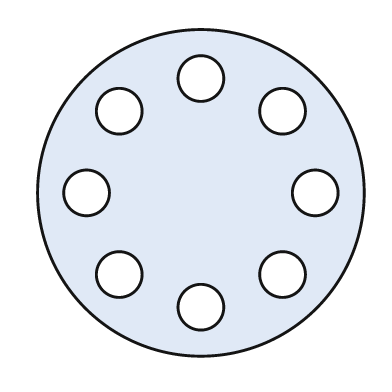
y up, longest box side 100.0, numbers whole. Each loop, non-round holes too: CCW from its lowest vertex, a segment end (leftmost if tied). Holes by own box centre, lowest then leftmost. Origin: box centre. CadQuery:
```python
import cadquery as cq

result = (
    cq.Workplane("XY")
    .moveTo(0.0, 0.0)
    .circle(50.0)
    .moveTo(0.0, -35.0)
    .circle(7.0)
    .moveTo(-25.0, -25.0)
    .circle(7.0)
    .moveTo(25.0, -25.0)
    .circle(7.0)
    .moveTo(-35.0, 0.0)
    .circle(7.0)
    .moveTo(35.0, 0.0)
    .circle(7.0)
    .moveTo(-25.0, 25.0)
    .circle(7.0)
    .moveTo(25.0, 25.0)
    .circle(7.0)
    .moveTo(0.0, 35.0)
    .circle(7.0)
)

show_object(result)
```